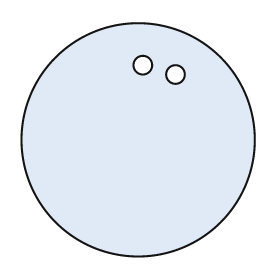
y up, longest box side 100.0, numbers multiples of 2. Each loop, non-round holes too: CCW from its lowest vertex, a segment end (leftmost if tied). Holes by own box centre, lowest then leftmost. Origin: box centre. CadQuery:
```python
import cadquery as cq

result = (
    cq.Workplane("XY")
    .moveTo(0.0, 0.0)
    .circle(50.0)
    .moveTo(16.0, 28.0)
    .circle(4.0)
    .moveTo(2.0, 32.0)
    .circle(4.0)
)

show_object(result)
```